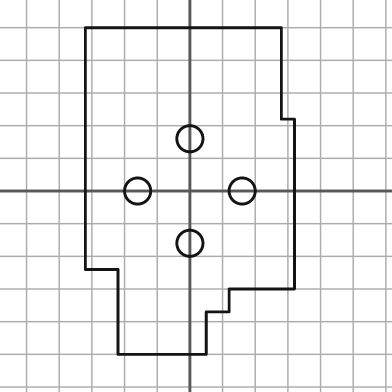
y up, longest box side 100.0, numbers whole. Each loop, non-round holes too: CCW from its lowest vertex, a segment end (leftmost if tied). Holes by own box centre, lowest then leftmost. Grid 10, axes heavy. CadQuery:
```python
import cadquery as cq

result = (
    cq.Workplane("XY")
    .moveTo(-22.0, -50.0)
    .lineTo(5.0, -50.0)
    .lineTo(5.0, -37.0)
    .lineTo(12.0, -37.0)
    .lineTo(12.0, -30.0)
    .lineTo(32.0, -30.0)
    .lineTo(32.0, 22.0)
    .lineTo(28.0, 22.0)
    .lineTo(28.0, 50.0)
    .lineTo(-32.0, 50.0)
    .lineTo(-32.0, -24.0)
    .lineTo(-22.0, -24.0)
    .close()
    .moveTo(0.0, -16.0)
    .circle(4.0)
    .moveTo(-16.0, 0.0)
    .circle(4.0)
    .moveTo(16.0, 0.0)
    .circle(4.0)
    .moveTo(0.0, 16.0)
    .circle(4.0)
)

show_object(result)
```